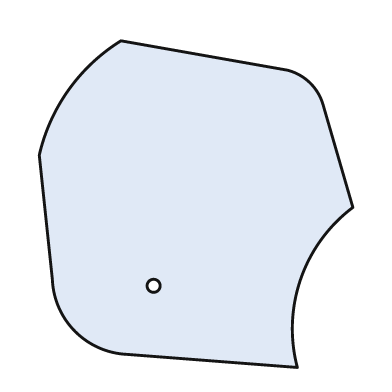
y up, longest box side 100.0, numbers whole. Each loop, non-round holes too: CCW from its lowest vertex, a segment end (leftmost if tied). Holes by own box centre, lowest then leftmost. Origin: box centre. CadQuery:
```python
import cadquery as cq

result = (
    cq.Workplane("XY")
    .moveTo(31.0, -50.0)
    .threePointArc((32.0, -23.0), (48.0, -1.0))
    .lineTo(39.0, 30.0)
    .threePointArc((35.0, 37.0), (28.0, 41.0))
    .lineTo(-23.0, 50.0)
    .threePointArc((-39.0, 35.0), (-48.0, 15.0))
    .lineTo(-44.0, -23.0)
    .threePointArc((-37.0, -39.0), (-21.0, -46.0))
    .close()
    .moveTo(-13.0, -25.0)
    .circle(2.0)
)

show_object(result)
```